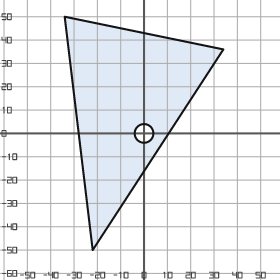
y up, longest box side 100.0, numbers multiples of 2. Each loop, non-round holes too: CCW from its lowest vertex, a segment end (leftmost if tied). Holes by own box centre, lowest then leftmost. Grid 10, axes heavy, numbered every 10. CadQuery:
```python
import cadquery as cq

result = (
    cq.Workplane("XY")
    .moveTo(-22.0, -50.0)
    .lineTo(34.0, 36.0)
    .lineTo(-34.0, 50.0)
    .close()
    .moveTo(0.0, 0.0)
    .circle(4.0)
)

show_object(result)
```